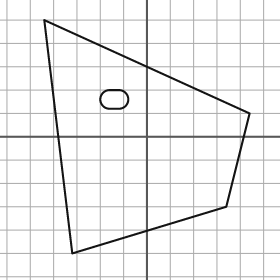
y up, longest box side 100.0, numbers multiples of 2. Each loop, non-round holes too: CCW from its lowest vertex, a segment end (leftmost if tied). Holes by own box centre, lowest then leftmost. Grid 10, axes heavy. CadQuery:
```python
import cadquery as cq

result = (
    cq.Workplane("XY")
    .moveTo(-32.0, -50.0)
    .lineTo(34.0, -30.0)
    .lineTo(44.0, 10.0)
    .lineTo(-44.0, 50.0)
    .close()
    .moveTo(-16.0, 12.0)
    .lineTo(-12.0, 12.0)
    .threePointArc((-8.0, 16.0), (-12.0, 20.0))
    .lineTo(-16.0, 20.0)
    .threePointArc((-20.0, 16.0), (-16.0, 12.0))
    .close()
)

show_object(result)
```